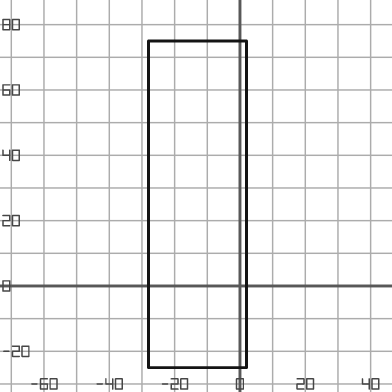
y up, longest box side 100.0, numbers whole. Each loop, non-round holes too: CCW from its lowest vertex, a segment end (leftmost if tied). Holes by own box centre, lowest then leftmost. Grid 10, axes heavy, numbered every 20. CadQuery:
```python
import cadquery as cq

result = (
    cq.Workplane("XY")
    .moveTo(-28.0, -25.0)
    .lineTo(2.0, -25.0)
    .lineTo(2.0, 75.0)
    .lineTo(-28.0, 75.0)
    .close()
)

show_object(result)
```